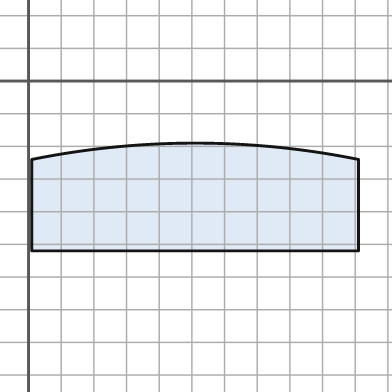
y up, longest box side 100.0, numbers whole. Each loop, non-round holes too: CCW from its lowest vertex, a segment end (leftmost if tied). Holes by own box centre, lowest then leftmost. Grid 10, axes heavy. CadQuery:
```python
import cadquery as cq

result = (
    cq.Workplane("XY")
    .moveTo(1.0, -52.0)
    .lineTo(101.0, -52.0)
    .lineTo(101.0, -24.0)
    .threePointArc((51.0, -19.0), (1.0, -24.0))
    .close()
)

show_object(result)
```